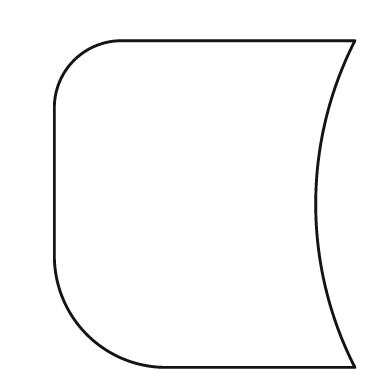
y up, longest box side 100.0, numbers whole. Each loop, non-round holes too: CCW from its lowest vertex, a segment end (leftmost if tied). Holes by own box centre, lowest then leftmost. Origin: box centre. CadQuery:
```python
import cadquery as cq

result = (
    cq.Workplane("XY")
    .moveTo(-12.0, -50.0)
    .lineTo(46.0, -50.0)
    .threePointArc((34.0, 0.0), (46.0, 50.0))
    .lineTo(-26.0, 50.0)
    .threePointArc((-40.0, 44.0), (-46.0, 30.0))
    .lineTo(-46.0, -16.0)
    .threePointArc((-36.0, -40.0), (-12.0, -50.0))
    .close()
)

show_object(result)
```